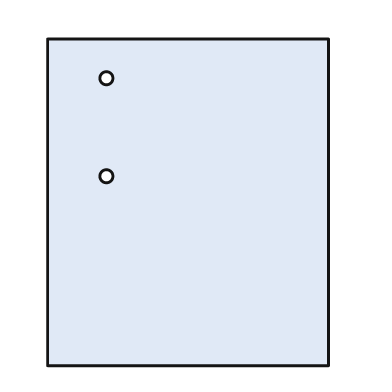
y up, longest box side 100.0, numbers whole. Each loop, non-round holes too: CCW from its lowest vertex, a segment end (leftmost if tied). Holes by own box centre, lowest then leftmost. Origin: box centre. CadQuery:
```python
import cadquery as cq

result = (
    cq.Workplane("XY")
    .moveTo(-43.0, -50.0)
    .lineTo(43.0, -50.0)
    .lineTo(43.0, 50.0)
    .lineTo(-43.0, 50.0)
    .close()
    .moveTo(-25.0, 8.0)
    .circle(2.0)
    .moveTo(-25.0, 38.0)
    .circle(2.0)
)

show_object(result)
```